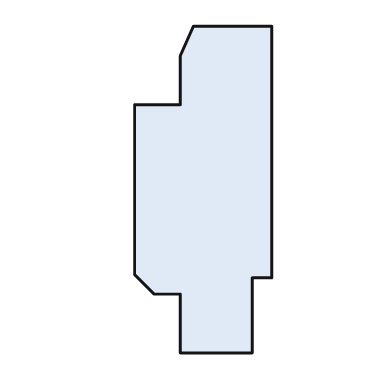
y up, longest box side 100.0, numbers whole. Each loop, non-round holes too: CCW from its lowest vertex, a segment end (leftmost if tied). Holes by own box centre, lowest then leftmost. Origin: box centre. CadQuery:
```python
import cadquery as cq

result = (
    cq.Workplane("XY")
    .moveTo(-7.0, -50.0)
    .lineTo(15.0, -50.0)
    .lineTo(15.0, -27.0)
    .lineTo(21.0, -27.0)
    .lineTo(21.0, 50.0)
    .lineTo(-3.0, 50.0)
    .lineTo(-7.0, 41.0)
    .lineTo(-7.0, 26.0)
    .lineTo(-21.0, 26.0)
    .lineTo(-21.0, -26.0)
    .lineTo(-15.0, -32.0)
    .lineTo(-7.0, -32.0)
    .close()
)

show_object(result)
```